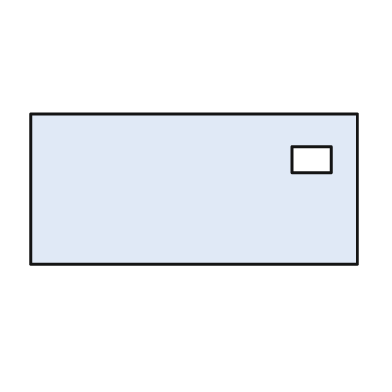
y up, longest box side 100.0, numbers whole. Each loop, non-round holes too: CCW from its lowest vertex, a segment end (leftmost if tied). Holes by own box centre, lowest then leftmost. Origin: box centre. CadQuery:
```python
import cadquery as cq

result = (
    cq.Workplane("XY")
    .moveTo(-50.0, -23.0)
    .lineTo(50.0, -23.0)
    .lineTo(50.0, 23.0)
    .lineTo(-50.0, 23.0)
    .close()
    .moveTo(30.0, 5.0)
    .lineTo(42.0, 5.0)
    .lineTo(42.0, 13.0)
    .lineTo(30.0, 13.0)
    .close()
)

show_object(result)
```